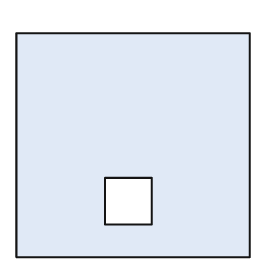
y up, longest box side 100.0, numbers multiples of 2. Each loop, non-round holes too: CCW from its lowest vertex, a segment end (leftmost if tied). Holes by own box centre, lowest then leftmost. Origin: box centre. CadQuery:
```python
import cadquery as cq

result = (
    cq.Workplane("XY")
    .moveTo(-50.0, -48.0)
    .lineTo(50.0, -48.0)
    .lineTo(50.0, 48.0)
    .lineTo(-50.0, 48.0)
    .close()
    .moveTo(-12.0, -34.0)
    .lineTo(8.0, -34.0)
    .lineTo(8.0, -14.0)
    .lineTo(-12.0, -14.0)
    .close()
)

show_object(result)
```